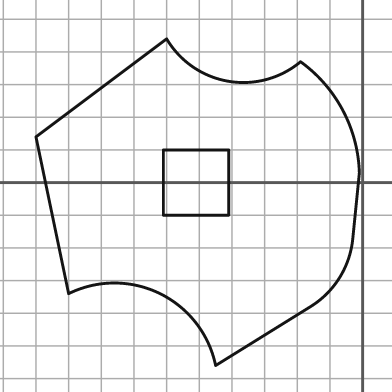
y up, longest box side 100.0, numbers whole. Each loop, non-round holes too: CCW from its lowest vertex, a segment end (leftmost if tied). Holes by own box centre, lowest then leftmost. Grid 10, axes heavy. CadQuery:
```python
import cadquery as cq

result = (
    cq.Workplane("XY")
    .moveTo(-45.0, -56.0)
    .lineTo(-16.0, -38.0)
    .threePointArc((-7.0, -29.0), (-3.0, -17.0))
    .lineTo(-1.0, 3.0)
    .threePointArc((-6.0, 22.0), (-19.0, 37.0))
    .threePointArc((-41.0, 31.0), (-60.0, 44.0))
    .lineTo(-100.0, 14.0)
    .lineTo(-90.0, -34.0)
    .threePointArc((-62.0, -34.0), (-45.0, -56.0))
    .close()
    .moveTo(-61.0, -10.0)
    .lineTo(-41.0, -10.0)
    .lineTo(-41.0, 10.0)
    .lineTo(-61.0, 10.0)
    .close()
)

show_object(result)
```